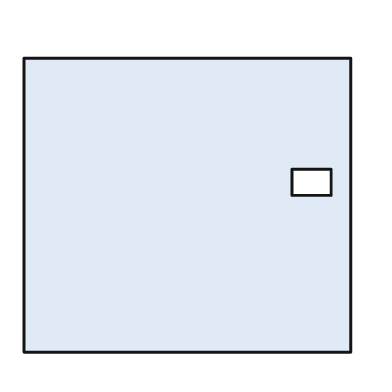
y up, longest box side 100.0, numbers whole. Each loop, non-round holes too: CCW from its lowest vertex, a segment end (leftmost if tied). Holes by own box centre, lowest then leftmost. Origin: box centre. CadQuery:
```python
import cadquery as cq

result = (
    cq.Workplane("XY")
    .moveTo(-50.0, -45.0)
    .lineTo(50.0, -45.0)
    .lineTo(50.0, 45.0)
    .lineTo(-50.0, 45.0)
    .close()
    .moveTo(32.0, 3.0)
    .lineTo(44.0, 3.0)
    .lineTo(44.0, 11.0)
    .lineTo(32.0, 11.0)
    .close()
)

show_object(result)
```